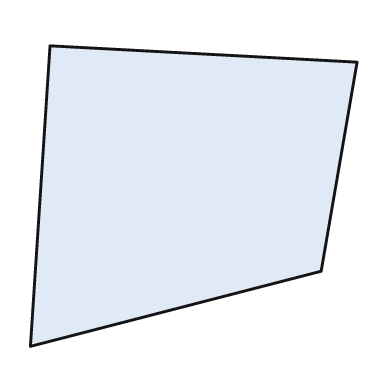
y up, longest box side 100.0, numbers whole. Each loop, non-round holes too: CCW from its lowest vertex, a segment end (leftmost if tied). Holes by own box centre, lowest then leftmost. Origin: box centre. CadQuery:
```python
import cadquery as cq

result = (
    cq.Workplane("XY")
    .moveTo(-50.0, -46.0)
    .lineTo(39.0, -23.0)
    .lineTo(50.0, 41.0)
    .lineTo(-44.0, 46.0)
    .close()
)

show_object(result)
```